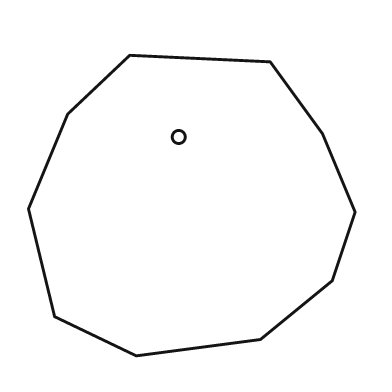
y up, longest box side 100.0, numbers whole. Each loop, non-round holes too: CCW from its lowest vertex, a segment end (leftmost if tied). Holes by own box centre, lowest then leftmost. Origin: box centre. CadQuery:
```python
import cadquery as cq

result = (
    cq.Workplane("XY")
    .moveTo(-17.0, -46.0)
    .lineTo(21.0, -41.0)
    .lineTo(43.0, -23.0)
    .lineTo(50.0, -2.0)
    .lineTo(40.0, 22.0)
    .lineTo(24.0, 44.0)
    .lineTo(-19.0, 46.0)
    .lineTo(-38.0, 28.0)
    .lineTo(-50.0, -1.0)
    .lineTo(-42.0, -34.0)
    .close()
    .moveTo(-4.0, 21.0)
    .circle(2.0)
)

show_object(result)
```